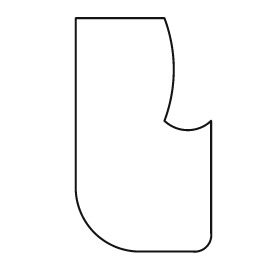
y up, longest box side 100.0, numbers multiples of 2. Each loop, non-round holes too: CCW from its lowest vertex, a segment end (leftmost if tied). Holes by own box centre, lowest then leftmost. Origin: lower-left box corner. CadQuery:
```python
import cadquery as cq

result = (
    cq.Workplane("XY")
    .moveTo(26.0, 0.0)
    .lineTo(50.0, 0.0)
    .threePointArc((56.0, 2.0), (58.0, 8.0))
    .lineTo(58.0, 56.0)
    .threePointArc((48.0, 52.0), (38.0, 56.0))
    .threePointArc((42.0, 78.0), (38.0, 100.0))
    .lineTo(0.0, 100.0)
    .lineTo(0.0, 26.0)
    .threePointArc((8.0, 8.0), (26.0, 0.0))
    .close()
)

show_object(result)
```